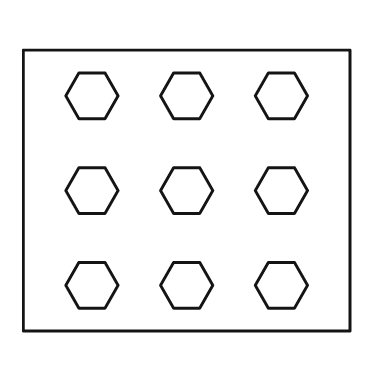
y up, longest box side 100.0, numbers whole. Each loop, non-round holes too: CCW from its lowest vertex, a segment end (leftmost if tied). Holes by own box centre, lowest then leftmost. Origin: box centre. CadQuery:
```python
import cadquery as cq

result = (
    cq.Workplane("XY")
    .moveTo(-50.0, -43.0)
    .lineTo(50.0, -43.0)
    .lineTo(50.0, 43.0)
    .lineTo(-50.0, 43.0)
    .close()
    .moveTo(-33.0, -36.0)
    .lineTo(-25.0, -36.0)
    .lineTo(-21.0, -29.0)
    .lineTo(-25.0, -22.0)
    .lineTo(-33.0, -22.0)
    .lineTo(-37.0, -29.0)
    .close()
    .moveTo(-4.0, -36.0)
    .lineTo(4.0, -36.0)
    .lineTo(8.0, -29.0)
    .lineTo(4.0, -22.0)
    .lineTo(-4.0, -22.0)
    .lineTo(-8.0, -29.0)
    .close()
    .moveTo(25.0, -36.0)
    .lineTo(33.0, -36.0)
    .lineTo(37.0, -29.0)
    .lineTo(33.0, -22.0)
    .lineTo(25.0, -22.0)
    .lineTo(21.0, -29.0)
    .close()
    .moveTo(-33.0, -7.0)
    .lineTo(-25.0, -7.0)
    .lineTo(-21.0, 0.0)
    .lineTo(-25.0, 7.0)
    .lineTo(-33.0, 7.0)
    .lineTo(-37.0, 0.0)
    .close()
    .moveTo(-4.0, -7.0)
    .lineTo(4.0, -7.0)
    .lineTo(8.0, 0.0)
    .lineTo(4.0, 7.0)
    .lineTo(-4.0, 7.0)
    .lineTo(-8.0, 0.0)
    .close()
    .moveTo(25.0, -7.0)
    .lineTo(33.0, -7.0)
    .lineTo(37.0, 0.0)
    .lineTo(33.0, 7.0)
    .lineTo(25.0, 7.0)
    .lineTo(21.0, 0.0)
    .close()
    .moveTo(-33.0, 22.0)
    .lineTo(-25.0, 22.0)
    .lineTo(-21.0, 29.0)
    .lineTo(-25.0, 36.0)
    .lineTo(-33.0, 36.0)
    .lineTo(-37.0, 29.0)
    .close()
    .moveTo(-4.0, 22.0)
    .lineTo(4.0, 22.0)
    .lineTo(8.0, 29.0)
    .lineTo(4.0, 36.0)
    .lineTo(-4.0, 36.0)
    .lineTo(-8.0, 29.0)
    .close()
    .moveTo(25.0, 22.0)
    .lineTo(33.0, 22.0)
    .lineTo(37.0, 29.0)
    .lineTo(33.0, 36.0)
    .lineTo(25.0, 36.0)
    .lineTo(21.0, 29.0)
    .close()
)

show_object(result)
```